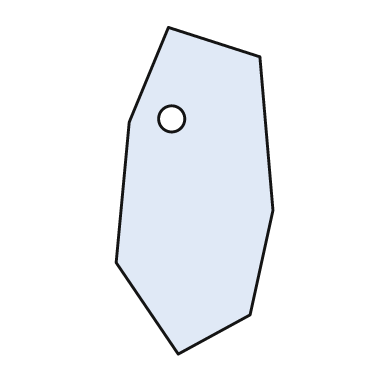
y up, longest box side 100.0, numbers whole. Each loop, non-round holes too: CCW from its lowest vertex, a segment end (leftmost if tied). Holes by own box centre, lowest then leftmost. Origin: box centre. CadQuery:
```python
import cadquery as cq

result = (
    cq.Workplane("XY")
    .moveTo(-5.0, -50.0)
    .lineTo(17.0, -38.0)
    .lineTo(24.0, -6.0)
    .lineTo(20.0, 41.0)
    .lineTo(-8.0, 50.0)
    .lineTo(-20.0, 21.0)
    .lineTo(-24.0, -22.0)
    .close()
    .moveTo(-7.0, 22.0)
    .circle(4.0)
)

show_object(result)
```